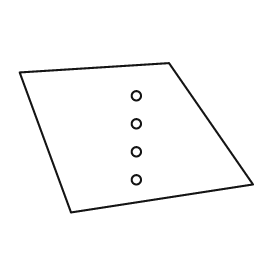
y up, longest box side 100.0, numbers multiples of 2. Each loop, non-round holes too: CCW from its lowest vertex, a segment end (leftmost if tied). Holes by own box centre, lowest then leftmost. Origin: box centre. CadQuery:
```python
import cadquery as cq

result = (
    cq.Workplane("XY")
    .moveTo(-28.0, -32.0)
    .lineTo(50.0, -20.0)
    .lineTo(14.0, 32.0)
    .lineTo(-50.0, 28.0)
    .close()
    .moveTo(0.0, -18.0)
    .circle(2.0)
    .moveTo(0.0, -6.0)
    .circle(2.0)
    .moveTo(0.0, 6.0)
    .circle(2.0)
    .moveTo(0.0, 18.0)
    .circle(2.0)
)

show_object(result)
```